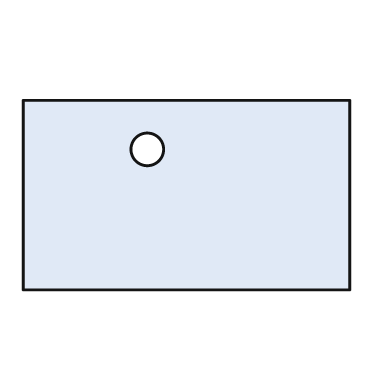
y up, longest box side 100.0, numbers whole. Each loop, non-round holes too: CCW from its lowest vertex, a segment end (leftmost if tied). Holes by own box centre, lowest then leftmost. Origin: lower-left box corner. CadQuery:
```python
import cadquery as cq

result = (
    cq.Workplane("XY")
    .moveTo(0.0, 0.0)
    .lineTo(100.0, 0.0)
    .lineTo(100.0, 58.0)
    .lineTo(0.0, 58.0)
    .close()
    .moveTo(38.0, 43.0)
    .circle(5.0)
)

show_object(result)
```